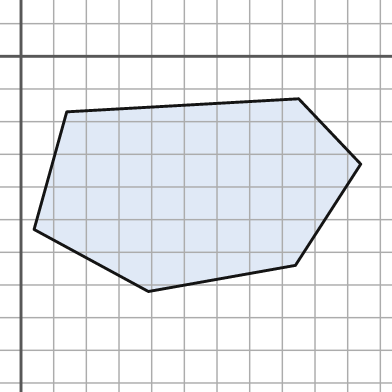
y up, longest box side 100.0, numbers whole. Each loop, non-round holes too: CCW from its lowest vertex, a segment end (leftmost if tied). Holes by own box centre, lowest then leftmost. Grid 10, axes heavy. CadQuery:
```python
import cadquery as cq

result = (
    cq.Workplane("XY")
    .moveTo(39.0, -72.0)
    .lineTo(84.0, -64.0)
    .lineTo(104.0, -33.0)
    .lineTo(85.0, -13.0)
    .lineTo(14.0, -17.0)
    .lineTo(4.0, -53.0)
    .close()
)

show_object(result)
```